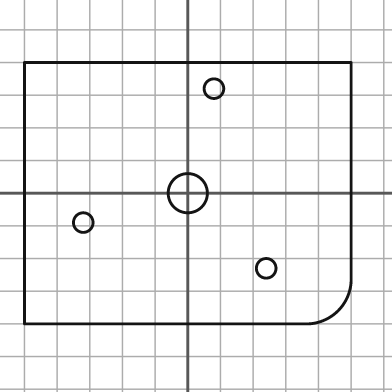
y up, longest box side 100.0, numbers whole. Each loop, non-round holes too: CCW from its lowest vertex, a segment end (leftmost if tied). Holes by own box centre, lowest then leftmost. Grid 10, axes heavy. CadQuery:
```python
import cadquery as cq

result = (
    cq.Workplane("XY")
    .moveTo(-50.0, -40.0)
    .lineTo(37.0, -40.0)
    .threePointArc((46.0, -36.0), (50.0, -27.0))
    .lineTo(50.0, 40.0)
    .lineTo(-50.0, 40.0)
    .close()
    .moveTo(24.0, -23.0)
    .circle(3.0)
    .moveTo(-32.0, -9.0)
    .circle(3.0)
    .moveTo(0.0, 0.0)
    .circle(6.0)
    .moveTo(8.0, 32.0)
    .circle(3.0)
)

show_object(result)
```